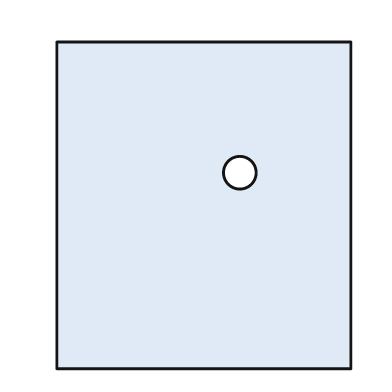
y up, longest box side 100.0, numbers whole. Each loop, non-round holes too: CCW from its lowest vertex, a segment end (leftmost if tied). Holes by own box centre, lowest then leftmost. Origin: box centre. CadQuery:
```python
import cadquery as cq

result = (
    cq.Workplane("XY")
    .moveTo(-45.0, -50.0)
    .lineTo(45.0, -50.0)
    .lineTo(45.0, 50.0)
    .lineTo(-45.0, 50.0)
    .close()
    .moveTo(11.0, 10.0)
    .circle(5.0)
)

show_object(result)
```